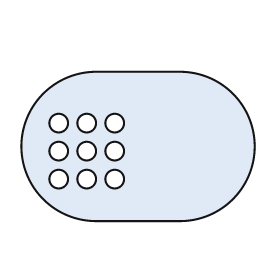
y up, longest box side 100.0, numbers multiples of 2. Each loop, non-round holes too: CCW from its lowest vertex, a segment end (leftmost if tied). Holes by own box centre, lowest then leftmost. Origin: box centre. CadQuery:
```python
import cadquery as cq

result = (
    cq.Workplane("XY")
    .moveTo(-18.0, -32.0)
    .lineTo(18.0, -32.0)
    .threePointArc((50.0, 0.0), (18.0, 32.0))
    .lineTo(-18.0, 32.0)
    .threePointArc((-50.0, 0.0), (-18.0, -32.0))
    .close()
    .moveTo(-34.0, -14.0)
    .circle(4.0)
    .moveTo(-22.0, -14.0)
    .circle(4.0)
    .moveTo(-10.0, -14.0)
    .circle(4.0)
    .moveTo(-34.0, -2.0)
    .circle(4.0)
    .moveTo(-22.0, -2.0)
    .circle(4.0)
    .moveTo(-10.0, -2.0)
    .circle(4.0)
    .moveTo(-34.0, 10.0)
    .circle(4.0)
    .moveTo(-22.0, 10.0)
    .circle(4.0)
    .moveTo(-10.0, 10.0)
    .circle(4.0)
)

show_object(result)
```